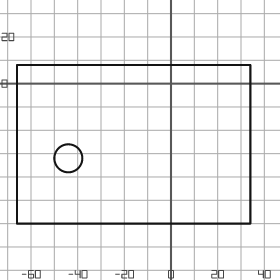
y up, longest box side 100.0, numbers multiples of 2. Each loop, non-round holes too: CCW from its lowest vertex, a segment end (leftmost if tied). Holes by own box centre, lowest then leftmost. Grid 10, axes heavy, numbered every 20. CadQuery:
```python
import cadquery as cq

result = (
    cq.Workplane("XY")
    .moveTo(-66.0, -60.0)
    .lineTo(34.0, -60.0)
    .lineTo(34.0, 8.0)
    .lineTo(-66.0, 8.0)
    .close()
    .moveTo(-44.0, -32.0)
    .circle(6.0)
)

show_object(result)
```